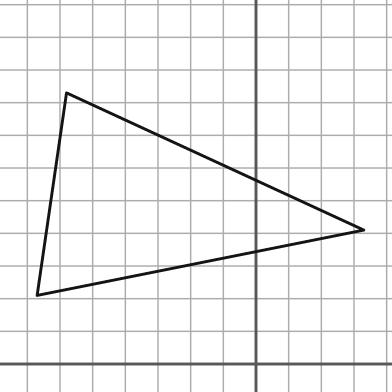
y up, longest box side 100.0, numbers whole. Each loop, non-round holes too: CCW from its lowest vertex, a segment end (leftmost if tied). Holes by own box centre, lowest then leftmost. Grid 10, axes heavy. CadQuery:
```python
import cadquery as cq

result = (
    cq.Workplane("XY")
    .moveTo(-67.0, 21.0)
    .lineTo(33.0, 41.0)
    .lineTo(-58.0, 83.0)
    .close()
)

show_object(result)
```